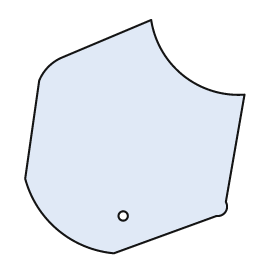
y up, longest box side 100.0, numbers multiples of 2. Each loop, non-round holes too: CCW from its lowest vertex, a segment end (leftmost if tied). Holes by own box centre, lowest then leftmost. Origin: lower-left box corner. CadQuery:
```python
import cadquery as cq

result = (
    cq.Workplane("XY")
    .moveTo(38.0, 0.0)
    .lineTo(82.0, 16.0)
    .threePointArc((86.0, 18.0), (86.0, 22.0))
    .lineTo(94.0, 68.0)
    .threePointArc((68.0, 76.0), (54.0, 100.0))
    .lineTo(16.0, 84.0)
    .threePointArc((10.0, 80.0), (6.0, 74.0))
    .lineTo(0.0, 32.0)
    .threePointArc((14.0, 10.0), (38.0, 0.0))
    .close()
    .moveTo(42.0, 16.0)
    .circle(2.0)
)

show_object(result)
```